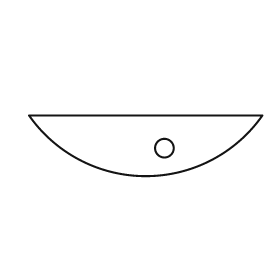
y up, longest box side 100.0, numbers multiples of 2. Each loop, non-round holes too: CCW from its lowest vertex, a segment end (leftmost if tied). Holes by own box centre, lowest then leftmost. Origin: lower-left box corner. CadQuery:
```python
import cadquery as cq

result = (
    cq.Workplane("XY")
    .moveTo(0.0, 26.0)
    .threePointArc((50.0, 0.0), (100.0, 26.0))
    .close()
    .moveTo(58.0, 12.0)
    .circle(4.0)
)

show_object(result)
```